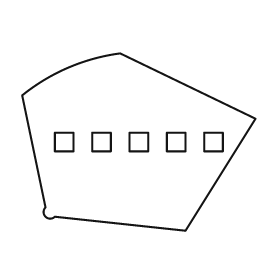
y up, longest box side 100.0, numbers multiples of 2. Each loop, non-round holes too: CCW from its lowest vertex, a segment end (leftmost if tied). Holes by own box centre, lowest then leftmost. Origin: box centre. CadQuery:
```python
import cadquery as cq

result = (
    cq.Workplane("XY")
    .moveTo(20.0, -38.0)
    .lineTo(50.0, 10.0)
    .lineTo(-8.0, 38.0)
    .threePointArc((-30.0, 32.0), (-50.0, 20.0))
    .lineTo(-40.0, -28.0)
    .threePointArc((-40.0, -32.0), (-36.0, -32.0))
    .close()
    .moveTo(-36.0, -4.0)
    .lineTo(-28.0, -4.0)
    .lineTo(-28.0, 4.0)
    .lineTo(-36.0, 4.0)
    .close()
    .moveTo(-20.0, -4.0)
    .lineTo(-12.0, -4.0)
    .lineTo(-12.0, 4.0)
    .lineTo(-20.0, 4.0)
    .close()
    .moveTo(-4.0, -4.0)
    .lineTo(4.0, -4.0)
    .lineTo(4.0, 4.0)
    .lineTo(-4.0, 4.0)
    .close()
    .moveTo(12.0, -4.0)
    .lineTo(20.0, -4.0)
    .lineTo(20.0, 4.0)
    .lineTo(12.0, 4.0)
    .close()
    .moveTo(28.0, -4.0)
    .lineTo(36.0, -4.0)
    .lineTo(36.0, 4.0)
    .lineTo(28.0, 4.0)
    .close()
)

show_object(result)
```